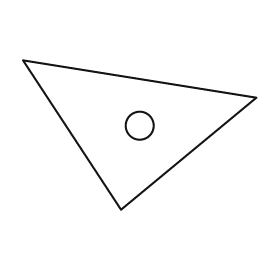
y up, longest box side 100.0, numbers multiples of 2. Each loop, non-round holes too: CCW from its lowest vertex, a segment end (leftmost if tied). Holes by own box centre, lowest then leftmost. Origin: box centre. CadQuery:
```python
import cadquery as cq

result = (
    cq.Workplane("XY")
    .moveTo(-8.0, -32.0)
    .lineTo(50.0, 16.0)
    .lineTo(-50.0, 32.0)
    .close()
    .moveTo(0.0, 4.0)
    .circle(6.0)
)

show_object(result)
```